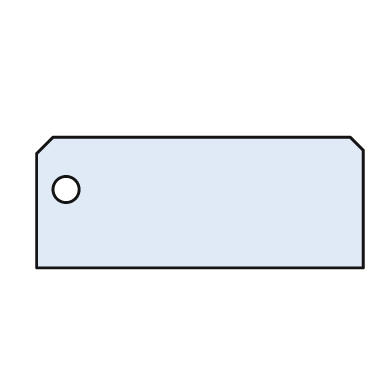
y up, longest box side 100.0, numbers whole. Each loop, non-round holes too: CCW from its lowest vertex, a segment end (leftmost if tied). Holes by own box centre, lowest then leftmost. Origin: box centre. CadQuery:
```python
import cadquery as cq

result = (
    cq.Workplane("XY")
    .moveTo(-50.0, -20.0)
    .lineTo(50.0, -20.0)
    .lineTo(50.0, 16.0)
    .lineTo(46.0, 20.0)
    .lineTo(-45.0, 20.0)
    .lineTo(-50.0, 15.0)
    .close()
    .moveTo(-41.0, 4.0)
    .circle(4.0)
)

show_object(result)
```